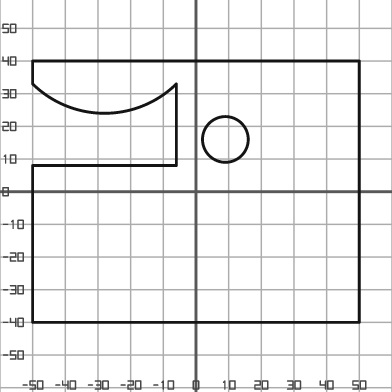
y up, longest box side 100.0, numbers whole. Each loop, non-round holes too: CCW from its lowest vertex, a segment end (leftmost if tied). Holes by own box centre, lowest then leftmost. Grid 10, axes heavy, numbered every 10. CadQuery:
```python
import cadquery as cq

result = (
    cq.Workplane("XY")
    .moveTo(-50.0, -40.0)
    .lineTo(50.0, -40.0)
    .lineTo(50.0, 40.0)
    .lineTo(-50.0, 40.0)
    .lineTo(-50.0, 33.0)
    .threePointArc((-28.0, 24.0), (-6.0, 33.0))
    .lineTo(-6.0, 8.0)
    .lineTo(-50.0, 8.0)
    .close()
    .moveTo(9.0, 16.0)
    .circle(7.0)
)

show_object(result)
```